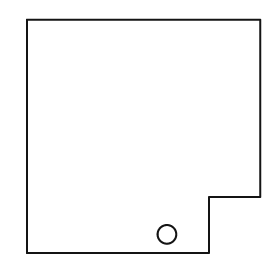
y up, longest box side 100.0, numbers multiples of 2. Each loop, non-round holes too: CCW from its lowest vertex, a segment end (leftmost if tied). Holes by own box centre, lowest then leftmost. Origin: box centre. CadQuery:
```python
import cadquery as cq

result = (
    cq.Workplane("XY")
    .moveTo(-50.0, -50.0)
    .lineTo(28.0, -50.0)
    .lineTo(28.0, -26.0)
    .lineTo(50.0, -26.0)
    .lineTo(50.0, 50.0)
    .lineTo(-50.0, 50.0)
    .close()
    .moveTo(10.0, -42.0)
    .circle(4.0)
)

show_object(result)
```